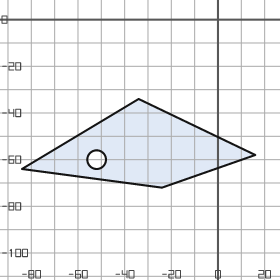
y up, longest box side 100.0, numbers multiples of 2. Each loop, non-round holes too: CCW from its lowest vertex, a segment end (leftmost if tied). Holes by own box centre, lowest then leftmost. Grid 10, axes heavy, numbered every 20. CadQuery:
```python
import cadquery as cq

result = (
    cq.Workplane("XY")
    .moveTo(-24.0, -72.0)
    .lineTo(16.0, -58.0)
    .lineTo(-34.0, -34.0)
    .lineTo(-84.0, -64.0)
    .close()
    .moveTo(-52.0, -60.0)
    .circle(4.0)
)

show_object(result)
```